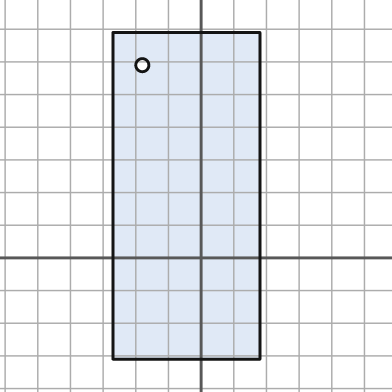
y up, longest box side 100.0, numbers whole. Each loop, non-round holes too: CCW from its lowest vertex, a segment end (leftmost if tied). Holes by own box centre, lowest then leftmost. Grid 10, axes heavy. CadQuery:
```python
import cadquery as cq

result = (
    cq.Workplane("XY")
    .moveTo(-27.0, -31.0)
    .lineTo(18.0, -31.0)
    .lineTo(18.0, 69.0)
    .lineTo(-27.0, 69.0)
    .close()
    .moveTo(-18.0, 59.0)
    .circle(2.0)
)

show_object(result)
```